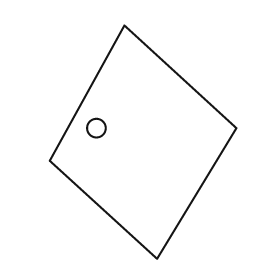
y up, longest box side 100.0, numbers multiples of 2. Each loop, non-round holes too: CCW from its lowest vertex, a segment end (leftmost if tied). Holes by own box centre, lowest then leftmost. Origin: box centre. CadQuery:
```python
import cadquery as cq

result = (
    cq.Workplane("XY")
    .moveTo(6.0, -50.0)
    .lineTo(40.0, 6.0)
    .lineTo(-8.0, 50.0)
    .lineTo(-40.0, -8.0)
    .close()
    .moveTo(-20.0, 6.0)
    .circle(4.0)
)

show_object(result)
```